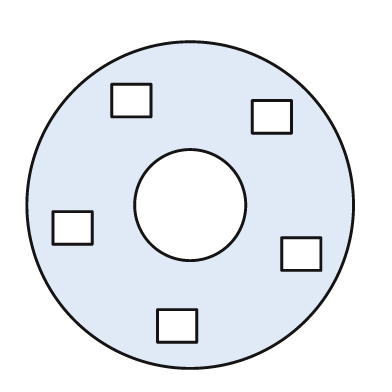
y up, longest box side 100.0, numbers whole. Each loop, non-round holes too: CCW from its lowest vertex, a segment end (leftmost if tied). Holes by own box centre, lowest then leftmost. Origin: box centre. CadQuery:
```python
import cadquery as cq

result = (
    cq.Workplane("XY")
    .moveTo(0.0, 0.0)
    .circle(50.0)
    .moveTo(-10.0, -42.0)
    .lineTo(2.0, -42.0)
    .lineTo(2.0, -32.0)
    .lineTo(-10.0, -32.0)
    .close()
    .moveTo(28.0, -20.0)
    .lineTo(40.0, -20.0)
    .lineTo(40.0, -10.0)
    .lineTo(28.0, -10.0)
    .close()
    .moveTo(-42.0, -12.0)
    .lineTo(-30.0, -12.0)
    .lineTo(-30.0, -2.0)
    .lineTo(-42.0, -2.0)
    .close()
    .moveTo(0.0, 0.0)
    .circle(17.0)
    .moveTo(19.0, 22.0)
    .lineTo(31.0, 22.0)
    .lineTo(31.0, 32.0)
    .lineTo(19.0, 32.0)
    .close()
    .moveTo(-24.0, 27.0)
    .lineTo(-12.0, 27.0)
    .lineTo(-12.0, 37.0)
    .lineTo(-24.0, 37.0)
    .close()
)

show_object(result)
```